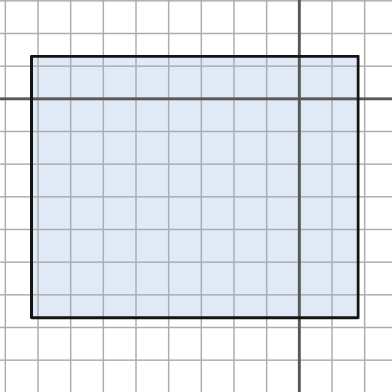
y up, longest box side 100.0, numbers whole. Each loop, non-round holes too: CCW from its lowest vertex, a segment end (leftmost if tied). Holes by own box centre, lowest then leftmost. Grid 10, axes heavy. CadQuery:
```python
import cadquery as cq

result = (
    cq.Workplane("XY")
    .moveTo(-82.0, -67.0)
    .lineTo(18.0, -67.0)
    .lineTo(18.0, 13.0)
    .lineTo(-82.0, 13.0)
    .close()
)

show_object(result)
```